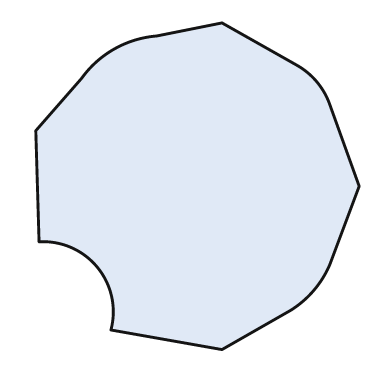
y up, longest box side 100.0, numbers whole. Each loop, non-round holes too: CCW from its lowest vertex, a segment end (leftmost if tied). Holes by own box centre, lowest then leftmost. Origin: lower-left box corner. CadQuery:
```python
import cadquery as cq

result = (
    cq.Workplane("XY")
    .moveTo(57.0, 0.0)
    .lineTo(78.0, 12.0)
    .threePointArc((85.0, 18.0), (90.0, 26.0))
    .lineTo(99.0, 50.0)
    .lineTo(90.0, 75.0)
    .threePointArc((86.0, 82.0), (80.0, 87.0))
    .lineTo(57.0, 100.0)
    .lineTo(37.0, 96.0)
    .threePointArc((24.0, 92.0), (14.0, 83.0))
    .lineTo(0.0, 67.0)
    .lineTo(1.0, 33.0)
    .threePointArc((19.0, 25.0), (23.0, 6.0))
    .close()
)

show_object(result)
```